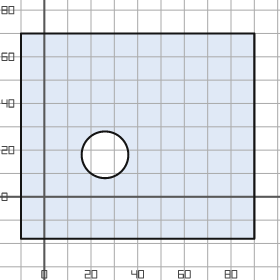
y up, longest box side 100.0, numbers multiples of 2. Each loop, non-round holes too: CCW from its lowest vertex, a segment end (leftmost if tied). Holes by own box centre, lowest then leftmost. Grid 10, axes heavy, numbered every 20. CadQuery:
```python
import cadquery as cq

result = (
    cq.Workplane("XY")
    .moveTo(-10.0, -18.0)
    .lineTo(90.0, -18.0)
    .lineTo(90.0, 70.0)
    .lineTo(-10.0, 70.0)
    .close()
    .moveTo(26.0, 18.0)
    .circle(10.0)
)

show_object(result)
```